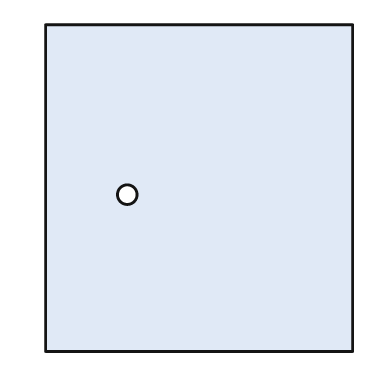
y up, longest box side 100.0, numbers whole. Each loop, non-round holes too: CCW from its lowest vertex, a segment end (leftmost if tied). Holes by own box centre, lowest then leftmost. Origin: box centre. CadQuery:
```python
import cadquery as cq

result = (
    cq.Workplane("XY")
    .moveTo(-47.0, -50.0)
    .lineTo(47.0, -50.0)
    .lineTo(47.0, 50.0)
    .lineTo(-47.0, 50.0)
    .close()
    .moveTo(-22.0, -2.0)
    .circle(3.0)
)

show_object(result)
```